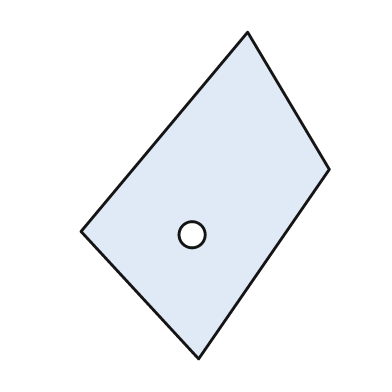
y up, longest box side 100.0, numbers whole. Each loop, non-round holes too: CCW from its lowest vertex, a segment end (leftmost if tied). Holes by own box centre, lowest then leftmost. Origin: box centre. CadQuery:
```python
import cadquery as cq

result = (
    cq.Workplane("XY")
    .moveTo(-2.0, -50.0)
    .lineTo(38.0, 8.0)
    .lineTo(13.0, 50.0)
    .lineTo(-38.0, -11.0)
    .close()
    .moveTo(-4.0, -12.0)
    .circle(4.0)
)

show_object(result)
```